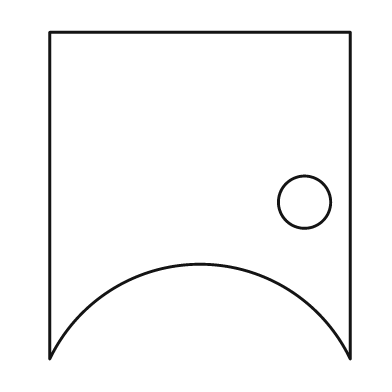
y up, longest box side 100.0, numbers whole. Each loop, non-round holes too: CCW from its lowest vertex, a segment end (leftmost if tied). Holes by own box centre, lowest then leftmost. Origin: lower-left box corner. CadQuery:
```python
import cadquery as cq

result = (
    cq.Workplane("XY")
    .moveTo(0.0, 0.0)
    .threePointArc((46.0, 29.0), (92.0, 0.0))
    .lineTo(92.0, 100.0)
    .lineTo(0.0, 100.0)
    .close()
    .moveTo(78.0, 48.0)
    .circle(8.0)
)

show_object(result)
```